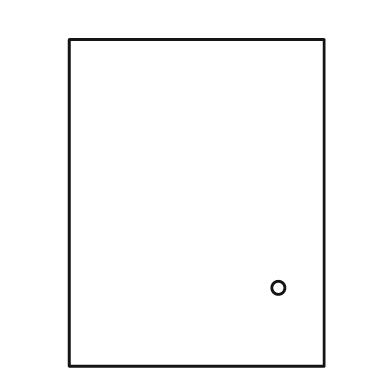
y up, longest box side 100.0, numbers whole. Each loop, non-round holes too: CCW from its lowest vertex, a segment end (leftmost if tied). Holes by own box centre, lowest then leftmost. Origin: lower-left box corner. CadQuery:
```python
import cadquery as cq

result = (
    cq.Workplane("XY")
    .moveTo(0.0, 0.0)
    .lineTo(78.0, 0.0)
    .lineTo(78.0, 100.0)
    .lineTo(0.0, 100.0)
    .close()
    .moveTo(64.0, 24.0)
    .circle(2.0)
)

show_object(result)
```